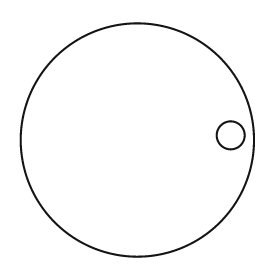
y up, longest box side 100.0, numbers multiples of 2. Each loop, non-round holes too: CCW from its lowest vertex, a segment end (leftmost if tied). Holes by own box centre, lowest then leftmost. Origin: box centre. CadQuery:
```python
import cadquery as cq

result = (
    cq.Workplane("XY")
    .moveTo(0.0, 0.0)
    .circle(50.0)
    .moveTo(40.0, 2.0)
    .circle(6.0)
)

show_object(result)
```